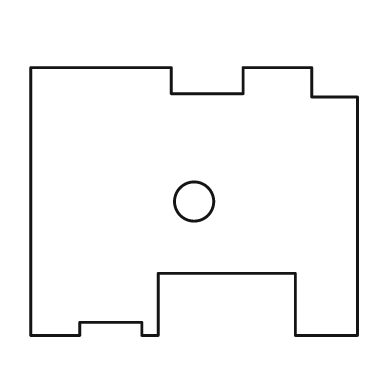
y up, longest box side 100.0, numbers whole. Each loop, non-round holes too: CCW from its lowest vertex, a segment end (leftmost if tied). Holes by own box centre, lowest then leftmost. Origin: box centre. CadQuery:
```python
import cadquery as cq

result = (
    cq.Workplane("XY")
    .moveTo(-50.0, -41.0)
    .lineTo(-35.0, -41.0)
    .lineTo(-35.0, -37.0)
    .lineTo(-16.0, -37.0)
    .lineTo(-16.0, -41.0)
    .lineTo(-11.0, -41.0)
    .lineTo(-11.0, -22.0)
    .lineTo(31.0, -22.0)
    .lineTo(31.0, -41.0)
    .lineTo(50.0, -41.0)
    .lineTo(50.0, 32.0)
    .lineTo(36.0, 32.0)
    .lineTo(36.0, 41.0)
    .lineTo(15.0, 41.0)
    .lineTo(15.0, 33.0)
    .lineTo(-7.0, 33.0)
    .lineTo(-7.0, 41.0)
    .lineTo(-50.0, 41.0)
    .close()
    .moveTo(0.0, 0.0)
    .circle(6.0)
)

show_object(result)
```